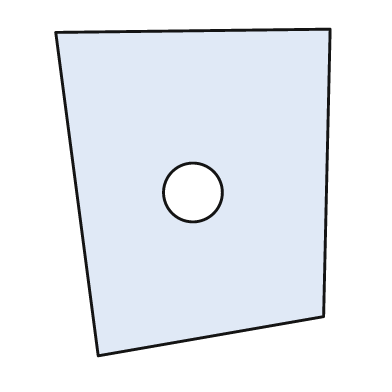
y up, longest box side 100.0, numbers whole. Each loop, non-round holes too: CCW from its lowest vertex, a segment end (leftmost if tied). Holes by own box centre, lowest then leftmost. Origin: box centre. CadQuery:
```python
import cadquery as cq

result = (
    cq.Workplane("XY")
    .moveTo(-29.0, -50.0)
    .lineTo(40.0, -38.0)
    .lineTo(42.0, 50.0)
    .lineTo(-42.0, 49.0)
    .close()
    .moveTo(0.0, 0.0)
    .circle(9.0)
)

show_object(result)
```